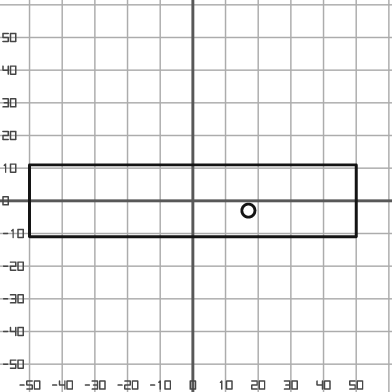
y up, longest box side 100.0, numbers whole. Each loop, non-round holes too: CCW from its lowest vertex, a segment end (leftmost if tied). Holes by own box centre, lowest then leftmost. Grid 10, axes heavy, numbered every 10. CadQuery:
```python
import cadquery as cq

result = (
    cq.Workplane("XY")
    .moveTo(-50.0, -11.0)
    .lineTo(50.0, -11.0)
    .lineTo(50.0, 11.0)
    .lineTo(-50.0, 11.0)
    .close()
    .moveTo(17.0, -3.0)
    .circle(2.0)
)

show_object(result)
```